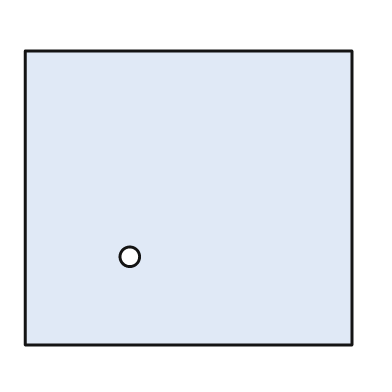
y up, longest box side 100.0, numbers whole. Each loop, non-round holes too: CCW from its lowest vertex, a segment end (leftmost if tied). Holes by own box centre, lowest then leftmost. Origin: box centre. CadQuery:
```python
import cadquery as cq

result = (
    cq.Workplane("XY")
    .moveTo(-50.0, -45.0)
    .lineTo(50.0, -45.0)
    .lineTo(50.0, 45.0)
    .lineTo(-50.0, 45.0)
    .close()
    .moveTo(-18.0, -18.0)
    .circle(3.0)
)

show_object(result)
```